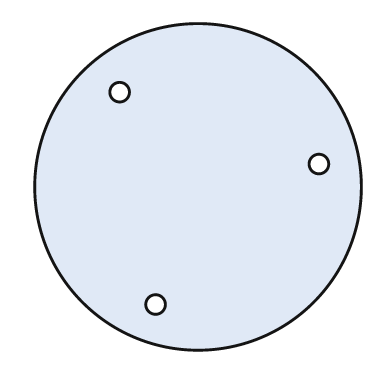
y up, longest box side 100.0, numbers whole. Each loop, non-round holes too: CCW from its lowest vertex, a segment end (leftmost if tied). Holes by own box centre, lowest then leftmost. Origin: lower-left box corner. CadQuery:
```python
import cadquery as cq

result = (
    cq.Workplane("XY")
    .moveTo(50.0, 50.0)
    .circle(50.0)
    .moveTo(37.0, 14.0)
    .circle(3.0)
    .moveTo(87.0, 57.0)
    .circle(3.0)
    .moveTo(26.0, 79.0)
    .circle(3.0)
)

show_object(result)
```